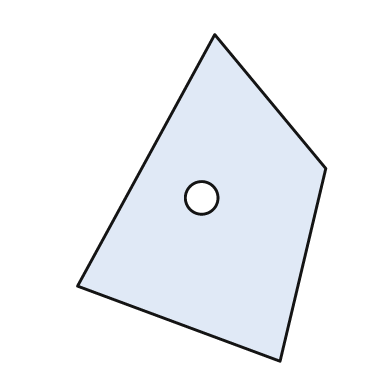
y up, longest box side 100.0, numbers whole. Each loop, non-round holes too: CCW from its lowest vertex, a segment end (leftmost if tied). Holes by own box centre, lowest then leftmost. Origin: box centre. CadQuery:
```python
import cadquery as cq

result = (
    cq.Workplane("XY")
    .moveTo(24.0, -50.0)
    .lineTo(38.0, 9.0)
    .lineTo(4.0, 50.0)
    .lineTo(-38.0, -27.0)
    .close()
    .moveTo(0.0, 0.0)
    .circle(5.0)
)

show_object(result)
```